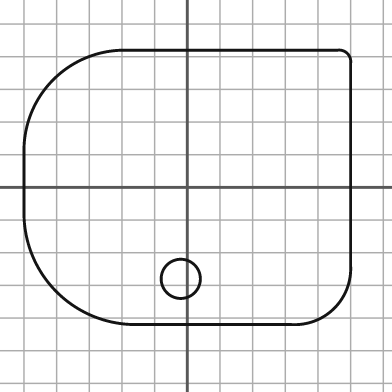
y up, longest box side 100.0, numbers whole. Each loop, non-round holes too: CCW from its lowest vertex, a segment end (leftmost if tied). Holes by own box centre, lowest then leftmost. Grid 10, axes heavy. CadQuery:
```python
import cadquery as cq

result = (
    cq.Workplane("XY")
    .moveTo(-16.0, -42.0)
    .lineTo(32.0, -42.0)
    .threePointArc((45.0, -37.0), (50.0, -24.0))
    .lineTo(50.0, 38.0)
    .threePointArc((49.0, 41.0), (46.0, 42.0))
    .lineTo(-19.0, 42.0)
    .threePointArc((-41.0, 33.0), (-50.0, 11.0))
    .lineTo(-50.0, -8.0)
    .threePointArc((-40.0, -32.0), (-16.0, -42.0))
    .close()
    .moveTo(-2.0, -28.0)
    .circle(6.0)
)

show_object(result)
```